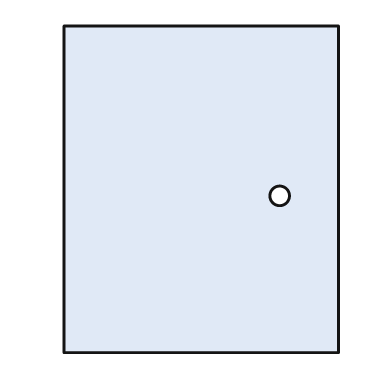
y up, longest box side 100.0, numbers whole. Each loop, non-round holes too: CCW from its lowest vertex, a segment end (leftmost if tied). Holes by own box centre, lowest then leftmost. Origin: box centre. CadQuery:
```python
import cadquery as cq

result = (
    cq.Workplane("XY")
    .moveTo(-42.0, -50.0)
    .lineTo(42.0, -50.0)
    .lineTo(42.0, 50.0)
    .lineTo(-42.0, 50.0)
    .close()
    .moveTo(24.0, -2.0)
    .circle(3.0)
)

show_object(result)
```